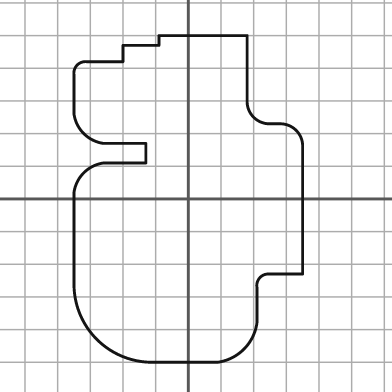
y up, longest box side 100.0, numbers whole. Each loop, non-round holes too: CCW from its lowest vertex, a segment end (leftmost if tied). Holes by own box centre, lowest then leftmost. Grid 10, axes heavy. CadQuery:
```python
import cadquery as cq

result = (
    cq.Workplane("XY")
    .moveTo(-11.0, -50.0)
    .lineTo(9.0, -50.0)
    .threePointArc((17.0, -46.0), (21.0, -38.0))
    .lineTo(21.0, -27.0)
    .threePointArc((22.0, -24.0), (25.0, -23.0))
    .lineTo(35.0, -23.0)
    .lineTo(35.0, 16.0)
    .threePointArc((33.0, 21.0), (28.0, 23.0))
    .lineTo(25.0, 23.0)
    .threePointArc((20.0, 25.0), (18.0, 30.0))
    .lineTo(18.0, 50.0)
    .lineTo(-9.0, 50.0)
    .lineTo(-9.0, 47.0)
    .lineTo(-20.0, 47.0)
    .lineTo(-20.0, 42.0)
    .lineTo(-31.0, 42.0)
    .threePointArc((-34.0, 41.0), (-35.0, 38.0))
    .lineTo(-35.0, 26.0)
    .threePointArc((-32.0, 20.0), (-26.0, 17.0))
    .lineTo(-13.0, 17.0)
    .lineTo(-13.0, 11.0)
    .lineTo(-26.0, 11.0)
    .threePointArc((-32.0, 8.0), (-35.0, 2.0))
    .lineTo(-35.0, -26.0)
    .threePointArc((-28.0, -43.0), (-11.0, -50.0))
    .close()
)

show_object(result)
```